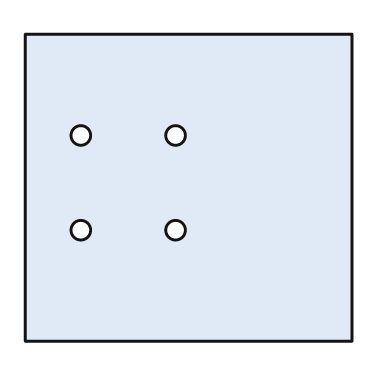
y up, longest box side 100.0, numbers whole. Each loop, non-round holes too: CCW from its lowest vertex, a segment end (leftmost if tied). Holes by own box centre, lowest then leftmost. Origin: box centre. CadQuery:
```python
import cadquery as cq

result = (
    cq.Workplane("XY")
    .moveTo(-50.0, -47.0)
    .lineTo(50.0, -47.0)
    .lineTo(50.0, 47.0)
    .lineTo(-50.0, 47.0)
    .close()
    .moveTo(-33.0, -13.0)
    .circle(3.0)
    .moveTo(-4.0, -13.0)
    .circle(3.0)
    .moveTo(-33.0, 16.0)
    .circle(3.0)
    .moveTo(-4.0, 16.0)
    .circle(3.0)
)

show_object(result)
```